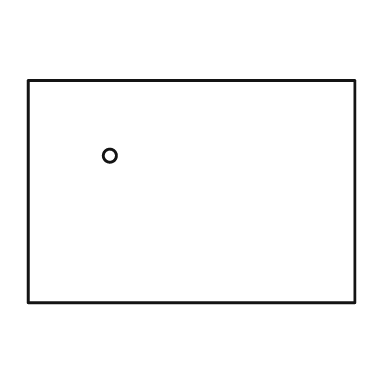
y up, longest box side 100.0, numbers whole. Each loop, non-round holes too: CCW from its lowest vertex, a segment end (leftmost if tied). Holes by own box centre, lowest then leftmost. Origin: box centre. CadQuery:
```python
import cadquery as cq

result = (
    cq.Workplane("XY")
    .moveTo(-50.0, -34.0)
    .lineTo(50.0, -34.0)
    .lineTo(50.0, 34.0)
    .lineTo(-50.0, 34.0)
    .close()
    .moveTo(-25.0, 11.0)
    .circle(2.0)
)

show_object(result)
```